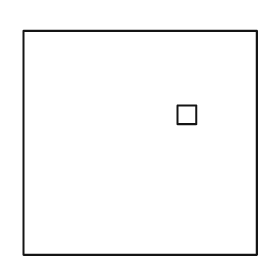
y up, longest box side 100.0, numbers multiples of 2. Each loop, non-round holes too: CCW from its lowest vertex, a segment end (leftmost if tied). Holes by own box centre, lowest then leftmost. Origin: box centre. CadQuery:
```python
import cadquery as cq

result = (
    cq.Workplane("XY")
    .moveTo(-50.0, -48.0)
    .lineTo(50.0, -48.0)
    .lineTo(50.0, 48.0)
    .lineTo(-50.0, 48.0)
    .close()
    .moveTo(16.0, 8.0)
    .lineTo(24.0, 8.0)
    .lineTo(24.0, 16.0)
    .lineTo(16.0, 16.0)
    .close()
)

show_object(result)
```